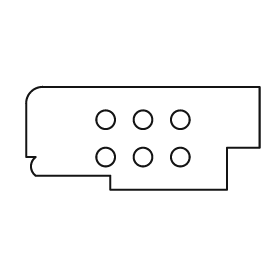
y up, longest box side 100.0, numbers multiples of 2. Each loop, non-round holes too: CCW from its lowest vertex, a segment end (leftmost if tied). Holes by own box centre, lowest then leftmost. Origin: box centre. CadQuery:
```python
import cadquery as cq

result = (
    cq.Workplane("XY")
    .moveTo(-14.0, -22.0)
    .lineTo(36.0, -22.0)
    .lineTo(36.0, -4.0)
    .lineTo(50.0, -4.0)
    .lineTo(50.0, 22.0)
    .lineTo(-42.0, 22.0)
    .threePointArc((-48.0, 20.0), (-50.0, 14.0))
    .lineTo(-50.0, -8.0)
    .lineTo(-46.0, -8.0)
    .threePointArc((-48.0, -12.0), (-46.0, -16.0))
    .lineTo(-14.0, -16.0)
    .close()
    .moveTo(-16.0, -8.0)
    .circle(4.0)
    .moveTo(0.0, -8.0)
    .circle(4.0)
    .moveTo(16.0, -8.0)
    .circle(4.0)
    .moveTo(-16.0, 8.0)
    .circle(4.0)
    .moveTo(0.0, 8.0)
    .circle(4.0)
    .moveTo(16.0, 8.0)
    .circle(4.0)
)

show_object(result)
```